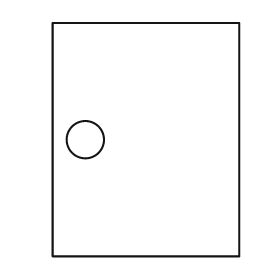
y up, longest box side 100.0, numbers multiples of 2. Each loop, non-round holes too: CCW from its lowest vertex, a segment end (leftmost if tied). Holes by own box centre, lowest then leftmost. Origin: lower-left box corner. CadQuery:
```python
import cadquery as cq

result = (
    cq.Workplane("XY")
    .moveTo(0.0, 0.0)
    .lineTo(80.0, 0.0)
    .lineTo(80.0, 100.0)
    .lineTo(0.0, 100.0)
    .close()
    .moveTo(14.0, 50.0)
    .circle(8.0)
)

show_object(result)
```